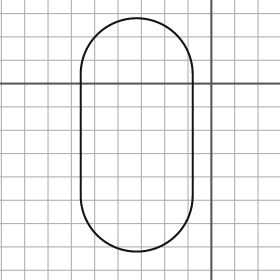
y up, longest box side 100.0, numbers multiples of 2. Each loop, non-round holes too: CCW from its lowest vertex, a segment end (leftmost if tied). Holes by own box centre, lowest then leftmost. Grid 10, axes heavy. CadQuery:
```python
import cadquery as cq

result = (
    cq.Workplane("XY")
    .moveTo(-56.0, -48.0)
    .threePointArc((-32.0, -72.0), (-8.0, -48.0))
    .lineTo(-8.0, 4.0)
    .threePointArc((-32.0, 28.0), (-56.0, 4.0))
    .close()
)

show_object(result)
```